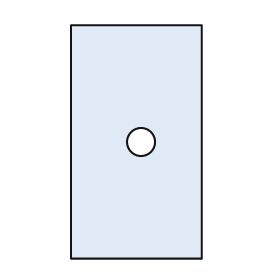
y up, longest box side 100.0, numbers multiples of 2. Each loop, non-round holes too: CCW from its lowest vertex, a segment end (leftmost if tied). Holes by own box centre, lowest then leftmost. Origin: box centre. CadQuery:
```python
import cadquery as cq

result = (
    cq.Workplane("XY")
    .moveTo(-28.0, -50.0)
    .lineTo(28.0, -50.0)
    .lineTo(28.0, 50.0)
    .lineTo(-28.0, 50.0)
    .close()
    .moveTo(2.0, 0.0)
    .circle(6.0)
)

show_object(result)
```